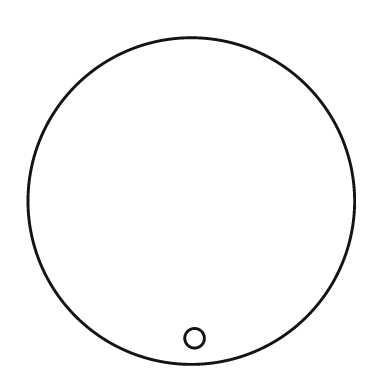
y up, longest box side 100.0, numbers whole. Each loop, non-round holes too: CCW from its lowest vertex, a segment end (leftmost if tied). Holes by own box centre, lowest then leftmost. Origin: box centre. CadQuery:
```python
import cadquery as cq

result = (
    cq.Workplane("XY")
    .moveTo(0.0, 0.0)
    .circle(50.0)
    .moveTo(1.0, -42.0)
    .circle(3.0)
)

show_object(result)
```